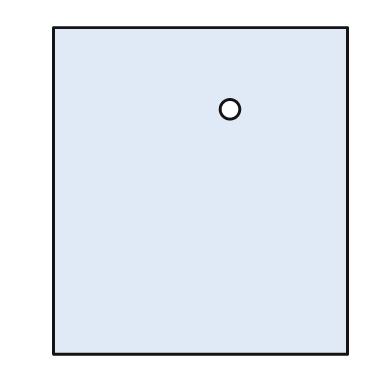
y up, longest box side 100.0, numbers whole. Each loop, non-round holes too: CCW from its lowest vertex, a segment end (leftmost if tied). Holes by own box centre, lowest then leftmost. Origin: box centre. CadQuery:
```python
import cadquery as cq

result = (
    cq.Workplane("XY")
    .moveTo(-45.0, -50.0)
    .lineTo(45.0, -50.0)
    .lineTo(45.0, 50.0)
    .lineTo(-45.0, 50.0)
    .close()
    .moveTo(9.0, 25.0)
    .circle(3.0)
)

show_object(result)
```